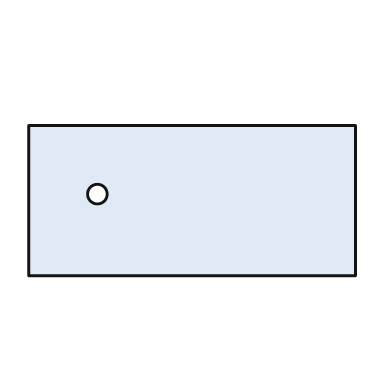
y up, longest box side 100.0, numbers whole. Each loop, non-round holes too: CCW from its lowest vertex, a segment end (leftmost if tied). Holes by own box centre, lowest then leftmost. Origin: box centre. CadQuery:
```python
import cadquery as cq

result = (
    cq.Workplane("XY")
    .moveTo(-50.0, -23.0)
    .lineTo(50.0, -23.0)
    .lineTo(50.0, 23.0)
    .lineTo(-50.0, 23.0)
    .close()
    .moveTo(-29.0, 2.0)
    .circle(3.0)
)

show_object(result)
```